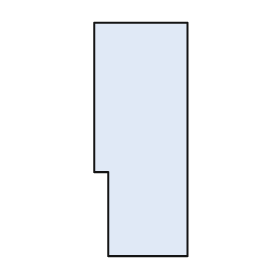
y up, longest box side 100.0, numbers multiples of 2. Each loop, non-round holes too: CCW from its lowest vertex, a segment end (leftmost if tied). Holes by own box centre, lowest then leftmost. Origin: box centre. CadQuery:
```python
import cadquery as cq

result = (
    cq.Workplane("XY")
    .moveTo(-14.0, -50.0)
    .lineTo(20.0, -50.0)
    .lineTo(20.0, 50.0)
    .lineTo(-20.0, 50.0)
    .lineTo(-20.0, -14.0)
    .lineTo(-14.0, -14.0)
    .close()
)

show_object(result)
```